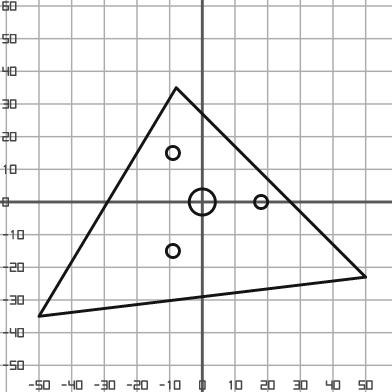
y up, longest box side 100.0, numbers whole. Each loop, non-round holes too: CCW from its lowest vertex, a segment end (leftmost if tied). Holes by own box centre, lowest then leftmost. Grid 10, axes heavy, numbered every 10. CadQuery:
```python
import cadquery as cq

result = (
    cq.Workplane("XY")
    .moveTo(-50.0, -35.0)
    .lineTo(50.0, -23.0)
    .lineTo(-8.0, 35.0)
    .close()
    .moveTo(-9.0, -15.0)
    .circle(2.0)
    .moveTo(0.0, 0.0)
    .circle(4.0)
    .moveTo(18.0, 0.0)
    .circle(2.0)
    .moveTo(-9.0, 15.0)
    .circle(2.0)
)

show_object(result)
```